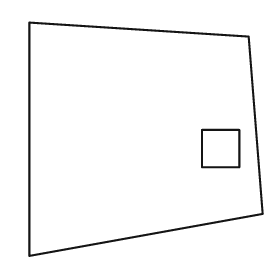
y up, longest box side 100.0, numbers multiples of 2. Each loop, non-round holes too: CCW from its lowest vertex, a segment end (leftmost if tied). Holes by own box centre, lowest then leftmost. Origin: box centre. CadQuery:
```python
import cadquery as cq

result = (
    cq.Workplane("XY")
    .moveTo(-50.0, -50.0)
    .lineTo(50.0, -32.0)
    .lineTo(44.0, 44.0)
    .lineTo(-50.0, 50.0)
    .close()
    .moveTo(24.0, -12.0)
    .lineTo(40.0, -12.0)
    .lineTo(40.0, 4.0)
    .lineTo(24.0, 4.0)
    .close()
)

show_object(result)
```